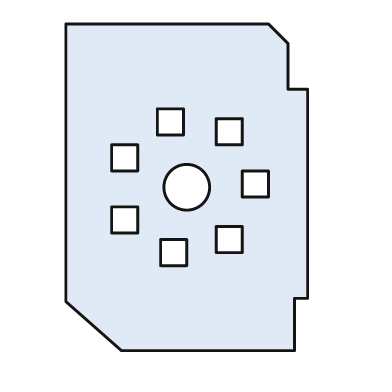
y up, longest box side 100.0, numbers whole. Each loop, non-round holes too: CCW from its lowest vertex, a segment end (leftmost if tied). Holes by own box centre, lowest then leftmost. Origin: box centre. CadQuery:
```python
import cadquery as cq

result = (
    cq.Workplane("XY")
    .moveTo(-20.0, -50.0)
    .lineTo(33.0, -50.0)
    .lineTo(33.0, -34.0)
    .lineTo(37.0, -34.0)
    .lineTo(37.0, 30.0)
    .lineTo(31.0, 30.0)
    .lineTo(31.0, 44.0)
    .lineTo(25.0, 50.0)
    .lineTo(-37.0, 50.0)
    .lineTo(-37.0, -35.0)
    .close()
    .moveTo(-8.0, -24.0)
    .lineTo(0.0, -24.0)
    .lineTo(0.0, -16.0)
    .lineTo(-8.0, -16.0)
    .close()
    .moveTo(9.0, -20.0)
    .lineTo(17.0, -20.0)
    .lineTo(17.0, -12.0)
    .lineTo(9.0, -12.0)
    .close()
    .moveTo(-23.0, -14.0)
    .lineTo(-15.0, -14.0)
    .lineTo(-15.0, -6.0)
    .lineTo(-23.0, -6.0)
    .close()
    .moveTo(0.0, 0.0)
    .circle(7.0)
    .moveTo(17.0, -3.0)
    .lineTo(25.0, -3.0)
    .lineTo(25.0, 5.0)
    .lineTo(17.0, 5.0)
    .close()
    .moveTo(-23.0, 5.0)
    .lineTo(-15.0, 5.0)
    .lineTo(-15.0, 13.0)
    .lineTo(-23.0, 13.0)
    .close()
    .moveTo(9.0, 13.0)
    .lineTo(17.0, 13.0)
    .lineTo(17.0, 21.0)
    .lineTo(9.0, 21.0)
    .close()
    .moveTo(-9.0, 16.0)
    .lineTo(-1.0, 16.0)
    .lineTo(-1.0, 24.0)
    .lineTo(-9.0, 24.0)
    .close()
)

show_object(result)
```